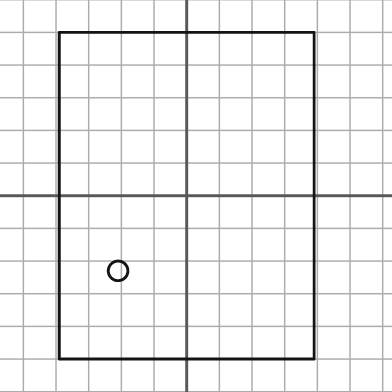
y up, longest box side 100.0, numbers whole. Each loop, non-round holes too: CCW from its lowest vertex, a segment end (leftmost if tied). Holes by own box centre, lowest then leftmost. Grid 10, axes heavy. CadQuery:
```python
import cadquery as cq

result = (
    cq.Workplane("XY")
    .moveTo(-39.0, -50.0)
    .lineTo(39.0, -50.0)
    .lineTo(39.0, 50.0)
    .lineTo(-39.0, 50.0)
    .close()
    .moveTo(-21.0, -23.0)
    .circle(3.0)
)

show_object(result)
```